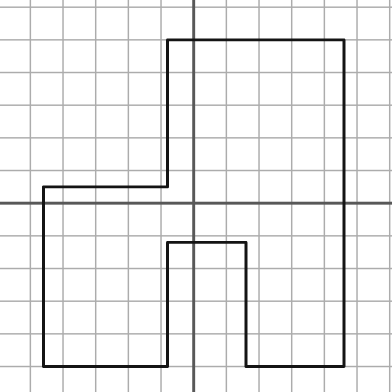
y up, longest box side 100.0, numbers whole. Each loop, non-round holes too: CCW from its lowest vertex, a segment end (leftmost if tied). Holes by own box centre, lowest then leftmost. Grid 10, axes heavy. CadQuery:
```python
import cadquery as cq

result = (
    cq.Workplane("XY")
    .moveTo(-46.0, -50.0)
    .lineTo(-8.0, -50.0)
    .lineTo(-8.0, -12.0)
    .lineTo(16.0, -12.0)
    .lineTo(16.0, -50.0)
    .lineTo(46.0, -50.0)
    .lineTo(46.0, 50.0)
    .lineTo(-8.0, 50.0)
    .lineTo(-8.0, 5.0)
    .lineTo(-46.0, 5.0)
    .close()
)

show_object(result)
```